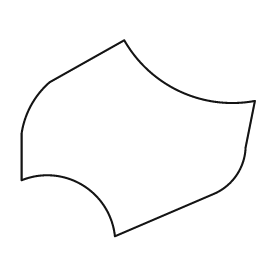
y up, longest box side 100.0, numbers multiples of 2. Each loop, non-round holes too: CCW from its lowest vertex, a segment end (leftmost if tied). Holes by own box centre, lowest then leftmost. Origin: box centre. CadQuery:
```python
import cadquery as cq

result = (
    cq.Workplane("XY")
    .moveTo(-10.0, -42.0)
    .lineTo(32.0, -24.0)
    .threePointArc((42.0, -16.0), (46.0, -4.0))
    .lineTo(50.0, 16.0)
    .threePointArc((18.0, 20.0), (-6.0, 42.0))
    .lineTo(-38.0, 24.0)
    .threePointArc((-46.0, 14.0), (-50.0, 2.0))
    .lineTo(-50.0, -18.0)
    .threePointArc((-24.0, -20.0), (-10.0, -42.0))
    .close()
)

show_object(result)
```